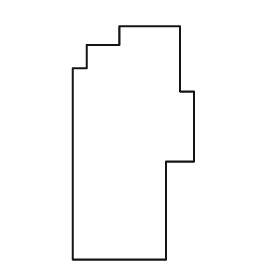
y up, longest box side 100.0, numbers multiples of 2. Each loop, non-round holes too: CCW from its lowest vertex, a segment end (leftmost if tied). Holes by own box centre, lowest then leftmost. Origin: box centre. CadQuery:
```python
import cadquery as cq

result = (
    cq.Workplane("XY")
    .moveTo(-26.0, -50.0)
    .lineTo(14.0, -50.0)
    .lineTo(14.0, -8.0)
    .lineTo(26.0, -8.0)
    .lineTo(26.0, 22.0)
    .lineTo(20.0, 22.0)
    .lineTo(20.0, 50.0)
    .lineTo(-6.0, 50.0)
    .lineTo(-6.0, 42.0)
    .lineTo(-20.0, 42.0)
    .lineTo(-20.0, 32.0)
    .lineTo(-26.0, 32.0)
    .close()
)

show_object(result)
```